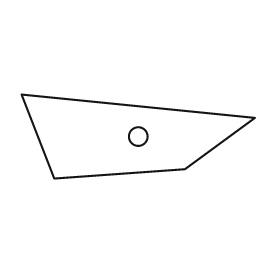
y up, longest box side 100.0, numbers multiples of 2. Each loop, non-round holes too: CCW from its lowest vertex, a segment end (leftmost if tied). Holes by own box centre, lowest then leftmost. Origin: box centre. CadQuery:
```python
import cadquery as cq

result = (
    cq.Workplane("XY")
    .moveTo(-36.0, -18.0)
    .lineTo(20.0, -14.0)
    .lineTo(50.0, 8.0)
    .lineTo(-50.0, 18.0)
    .close()
    .moveTo(0.0, 0.0)
    .circle(4.0)
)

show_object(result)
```